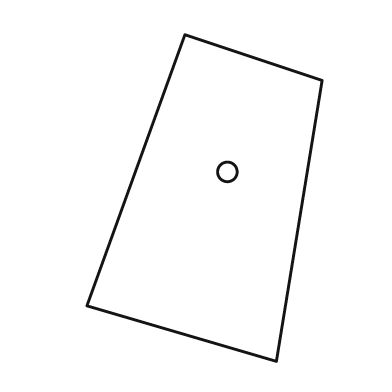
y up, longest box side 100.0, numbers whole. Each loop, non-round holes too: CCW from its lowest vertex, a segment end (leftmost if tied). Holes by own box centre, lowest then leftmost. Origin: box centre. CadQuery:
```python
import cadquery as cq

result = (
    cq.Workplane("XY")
    .moveTo(22.0, -50.0)
    .lineTo(36.0, 36.0)
    .lineTo(-6.0, 50.0)
    .lineTo(-36.0, -33.0)
    .close()
    .moveTo(7.0, 8.0)
    .circle(3.0)
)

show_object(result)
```